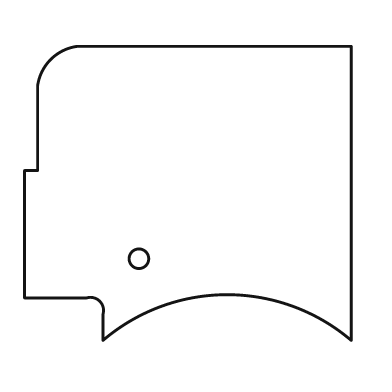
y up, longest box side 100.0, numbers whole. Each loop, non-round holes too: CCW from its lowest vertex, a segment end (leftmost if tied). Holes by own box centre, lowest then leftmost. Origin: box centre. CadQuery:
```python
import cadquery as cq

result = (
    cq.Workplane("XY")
    .moveTo(-26.0, -45.0)
    .threePointArc((12.0, -31.0), (50.0, -45.0))
    .lineTo(50.0, 45.0)
    .lineTo(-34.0, 45.0)
    .threePointArc((-42.0, 41.0), (-46.0, 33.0))
    .lineTo(-46.0, 7.0)
    .lineTo(-50.0, 7.0)
    .lineTo(-50.0, -32.0)
    .lineTo(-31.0, -32.0)
    .threePointArc((-27.0, -33.0), (-26.0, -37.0))
    .close()
    .moveTo(-15.0, -20.0)
    .circle(3.0)
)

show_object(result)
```